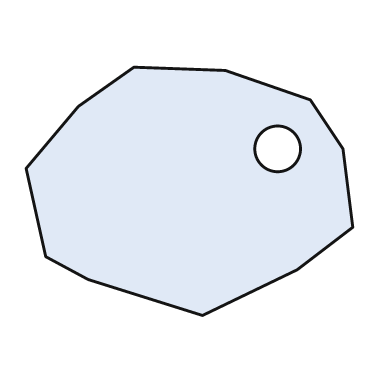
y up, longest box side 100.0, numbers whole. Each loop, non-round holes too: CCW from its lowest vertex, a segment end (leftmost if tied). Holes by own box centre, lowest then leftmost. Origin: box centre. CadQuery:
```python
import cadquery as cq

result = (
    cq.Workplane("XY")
    .moveTo(4.0, -38.0)
    .lineTo(33.0, -24.0)
    .lineTo(50.0, -11.0)
    .lineTo(47.0, 13.0)
    .lineTo(37.0, 28.0)
    .lineTo(11.0, 37.0)
    .lineTo(-17.0, 38.0)
    .lineTo(-34.0, 26.0)
    .lineTo(-50.0, 7.0)
    .lineTo(-44.0, -20.0)
    .lineTo(-31.0, -27.0)
    .close()
    .moveTo(27.0, 13.0)
    .circle(7.0)
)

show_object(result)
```